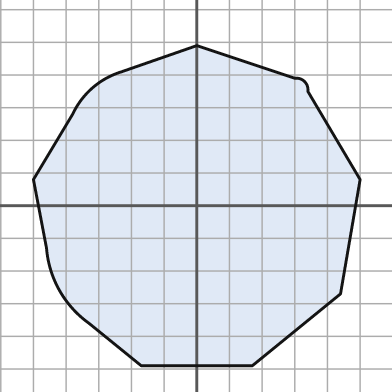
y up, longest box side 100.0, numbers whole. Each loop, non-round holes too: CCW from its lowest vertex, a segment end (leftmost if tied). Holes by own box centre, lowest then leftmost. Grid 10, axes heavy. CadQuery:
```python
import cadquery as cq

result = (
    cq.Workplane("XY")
    .moveTo(-17.0, -49.0)
    .lineTo(17.0, -49.0)
    .lineTo(44.0, -27.0)
    .lineTo(50.0, 8.0)
    .lineTo(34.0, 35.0)
    .threePointArc((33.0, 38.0), (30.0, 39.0))
    .lineTo(0.0, 49.0)
    .lineTo(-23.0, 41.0)
    .threePointArc((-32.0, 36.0), (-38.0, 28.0))
    .lineTo(-50.0, 8.0)
    .lineTo(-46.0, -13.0)
    .threePointArc((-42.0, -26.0), (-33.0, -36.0))
    .close()
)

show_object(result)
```